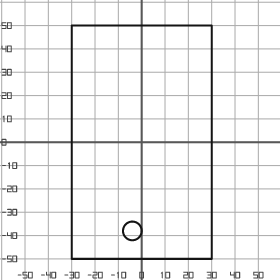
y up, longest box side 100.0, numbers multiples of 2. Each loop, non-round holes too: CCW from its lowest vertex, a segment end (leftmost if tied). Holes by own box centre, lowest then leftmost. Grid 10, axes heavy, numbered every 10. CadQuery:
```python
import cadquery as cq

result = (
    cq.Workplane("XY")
    .moveTo(-30.0, -50.0)
    .lineTo(30.0, -50.0)
    .lineTo(30.0, 50.0)
    .lineTo(-30.0, 50.0)
    .close()
    .moveTo(-4.0, -38.0)
    .circle(4.0)
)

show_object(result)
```